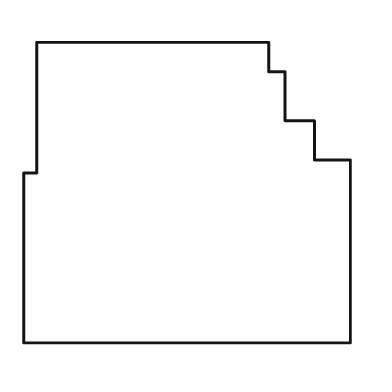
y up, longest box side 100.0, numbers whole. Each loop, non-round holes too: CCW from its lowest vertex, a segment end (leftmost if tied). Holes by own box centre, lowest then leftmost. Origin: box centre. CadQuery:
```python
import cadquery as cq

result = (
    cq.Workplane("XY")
    .moveTo(-50.0, -46.0)
    .lineTo(50.0, -46.0)
    .lineTo(50.0, 10.0)
    .lineTo(39.0, 10.0)
    .lineTo(39.0, 22.0)
    .lineTo(30.0, 22.0)
    .lineTo(30.0, 37.0)
    .lineTo(25.0, 37.0)
    .lineTo(25.0, 46.0)
    .lineTo(-46.0, 46.0)
    .lineTo(-46.0, 6.0)
    .lineTo(-50.0, 6.0)
    .close()
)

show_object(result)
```